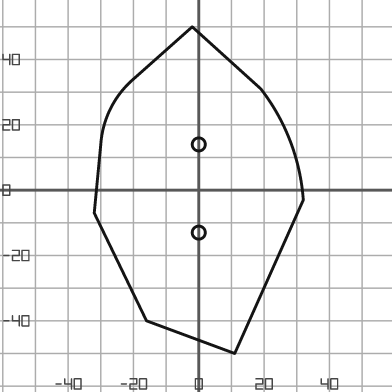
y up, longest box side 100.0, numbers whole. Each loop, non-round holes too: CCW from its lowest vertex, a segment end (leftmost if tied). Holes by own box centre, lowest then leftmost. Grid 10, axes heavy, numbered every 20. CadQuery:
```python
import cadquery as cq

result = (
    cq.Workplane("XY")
    .moveTo(11.0, -50.0)
    .lineTo(32.0, -3.0)
    .threePointArc((28.0, 15.0), (19.0, 31.0))
    .lineTo(-2.0, 50.0)
    .lineTo(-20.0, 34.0)
    .threePointArc((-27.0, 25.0), (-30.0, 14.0))
    .lineTo(-32.0, -7.0)
    .lineTo(-16.0, -40.0)
    .close()
    .moveTo(0.0, -13.0)
    .circle(2.0)
    .moveTo(0.0, 14.0)
    .circle(2.0)
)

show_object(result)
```